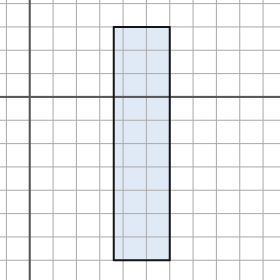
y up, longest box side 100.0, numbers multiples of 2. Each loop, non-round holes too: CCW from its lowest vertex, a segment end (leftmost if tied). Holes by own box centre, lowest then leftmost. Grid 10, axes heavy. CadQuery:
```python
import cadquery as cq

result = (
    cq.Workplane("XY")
    .moveTo(36.0, -70.0)
    .lineTo(60.0, -70.0)
    .lineTo(60.0, 30.0)
    .lineTo(36.0, 30.0)
    .close()
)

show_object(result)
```